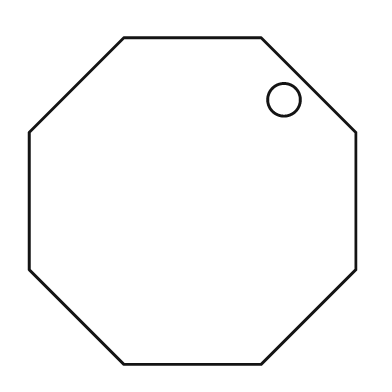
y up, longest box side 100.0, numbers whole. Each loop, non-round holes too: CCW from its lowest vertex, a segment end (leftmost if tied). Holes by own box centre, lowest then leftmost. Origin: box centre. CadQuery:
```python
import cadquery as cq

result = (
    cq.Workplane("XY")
    .moveTo(-21.0, -50.0)
    .lineTo(21.0, -50.0)
    .lineTo(50.0, -21.0)
    .lineTo(50.0, 21.0)
    .lineTo(21.0, 50.0)
    .lineTo(-21.0, 50.0)
    .lineTo(-50.0, 21.0)
    .lineTo(-50.0, -21.0)
    .close()
    .moveTo(28.0, 31.0)
    .circle(5.0)
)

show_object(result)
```